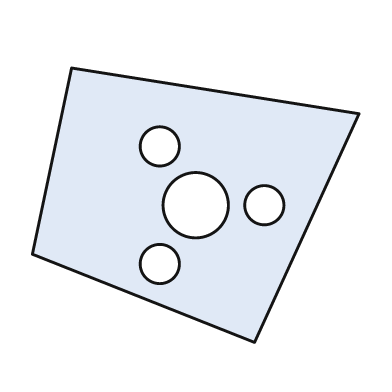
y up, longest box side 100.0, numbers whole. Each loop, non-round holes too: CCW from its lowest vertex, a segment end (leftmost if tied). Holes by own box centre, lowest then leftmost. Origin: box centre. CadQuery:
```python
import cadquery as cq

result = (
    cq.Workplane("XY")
    .moveTo(18.0, -42.0)
    .lineTo(50.0, 28.0)
    .lineTo(-38.0, 42.0)
    .lineTo(-50.0, -15.0)
    .close()
    .moveTo(-11.0, -18.0)
    .circle(6.0)
    .moveTo(0.0, 0.0)
    .circle(10.0)
    .moveTo(21.0, 0.0)
    .circle(6.0)
    .moveTo(-11.0, 18.0)
    .circle(6.0)
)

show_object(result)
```